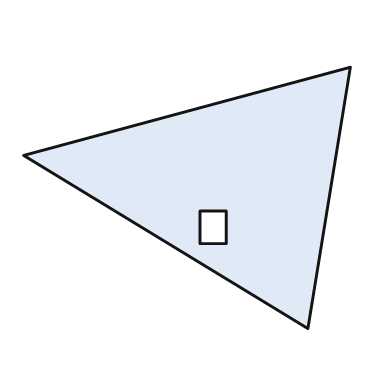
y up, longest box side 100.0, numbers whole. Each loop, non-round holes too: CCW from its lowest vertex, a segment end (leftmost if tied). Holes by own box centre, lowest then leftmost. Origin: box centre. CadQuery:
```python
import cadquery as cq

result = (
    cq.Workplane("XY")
    .moveTo(37.0, -40.0)
    .lineTo(50.0, 40.0)
    .lineTo(-50.0, 13.0)
    .close()
    .moveTo(4.0, -14.0)
    .lineTo(12.0, -14.0)
    .lineTo(12.0, -4.0)
    .lineTo(4.0, -4.0)
    .close()
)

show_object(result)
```